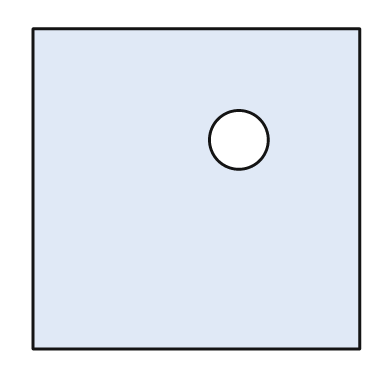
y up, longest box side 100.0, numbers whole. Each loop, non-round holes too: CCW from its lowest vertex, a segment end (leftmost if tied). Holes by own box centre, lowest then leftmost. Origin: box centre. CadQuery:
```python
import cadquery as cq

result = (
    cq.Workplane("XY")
    .moveTo(-50.0, -49.0)
    .lineTo(50.0, -49.0)
    .lineTo(50.0, 49.0)
    .lineTo(-50.0, 49.0)
    .close()
    .moveTo(13.0, 15.0)
    .circle(9.0)
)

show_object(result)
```